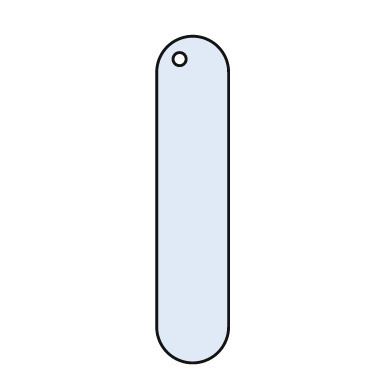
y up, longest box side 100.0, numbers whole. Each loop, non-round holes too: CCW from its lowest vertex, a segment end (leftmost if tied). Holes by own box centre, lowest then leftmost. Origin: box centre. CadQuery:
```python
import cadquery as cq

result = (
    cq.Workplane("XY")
    .moveTo(-11.0, -39.0)
    .threePointArc((0.0, -50.0), (11.0, -39.0))
    .lineTo(11.0, 39.0)
    .threePointArc((0.0, 50.0), (-11.0, 39.0))
    .close()
    .moveTo(-4.0, 43.0)
    .circle(2.0)
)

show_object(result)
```